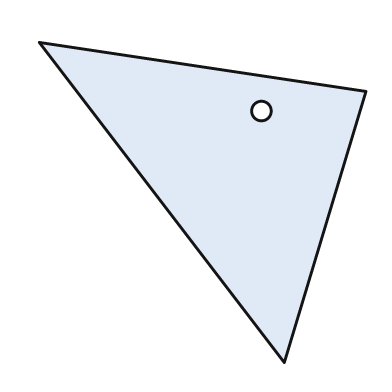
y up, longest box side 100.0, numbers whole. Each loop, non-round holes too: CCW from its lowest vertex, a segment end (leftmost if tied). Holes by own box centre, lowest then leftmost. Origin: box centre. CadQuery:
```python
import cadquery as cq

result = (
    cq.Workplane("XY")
    .moveTo(25.0, -49.0)
    .lineTo(50.0, 34.0)
    .lineTo(-50.0, 49.0)
    .close()
    .moveTo(18.0, 28.0)
    .circle(3.0)
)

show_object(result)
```